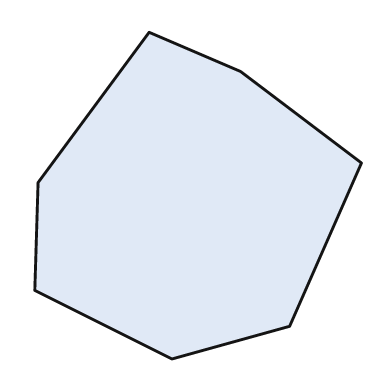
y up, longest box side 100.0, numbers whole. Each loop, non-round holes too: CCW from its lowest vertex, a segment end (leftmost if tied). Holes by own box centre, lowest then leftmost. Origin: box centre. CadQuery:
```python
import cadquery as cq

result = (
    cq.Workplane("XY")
    .moveTo(-8.0, -50.0)
    .lineTo(28.0, -40.0)
    .lineTo(50.0, 10.0)
    .lineTo(13.0, 38.0)
    .lineTo(-15.0, 50.0)
    .lineTo(-49.0, 4.0)
    .lineTo(-50.0, -29.0)
    .close()
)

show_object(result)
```